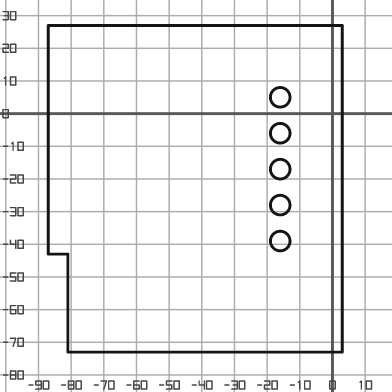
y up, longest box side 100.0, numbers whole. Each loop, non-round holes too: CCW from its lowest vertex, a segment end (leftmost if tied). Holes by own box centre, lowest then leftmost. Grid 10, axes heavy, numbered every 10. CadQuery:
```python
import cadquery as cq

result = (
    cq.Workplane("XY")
    .moveTo(-81.0, -73.0)
    .lineTo(3.0, -73.0)
    .lineTo(3.0, 27.0)
    .lineTo(-87.0, 27.0)
    .lineTo(-87.0, -43.0)
    .lineTo(-81.0, -43.0)
    .close()
    .moveTo(-16.0, -39.0)
    .circle(3.0)
    .moveTo(-16.0, -28.0)
    .circle(3.0)
    .moveTo(-16.0, -17.0)
    .circle(3.0)
    .moveTo(-16.0, -6.0)
    .circle(3.0)
    .moveTo(-16.0, 5.0)
    .circle(3.0)
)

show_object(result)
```